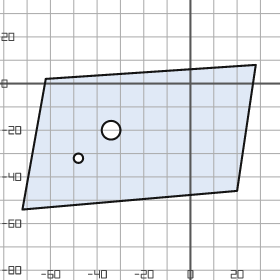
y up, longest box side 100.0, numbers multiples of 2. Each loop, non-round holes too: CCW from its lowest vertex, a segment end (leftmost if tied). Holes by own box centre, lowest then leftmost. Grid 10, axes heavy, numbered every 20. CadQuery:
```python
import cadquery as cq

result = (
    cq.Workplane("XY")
    .moveTo(-72.0, -54.0)
    .lineTo(20.0, -46.0)
    .lineTo(28.0, 8.0)
    .lineTo(-62.0, 2.0)
    .close()
    .moveTo(-48.0, -32.0)
    .circle(2.0)
    .moveTo(-34.0, -20.0)
    .circle(4.0)
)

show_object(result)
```